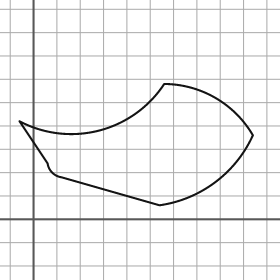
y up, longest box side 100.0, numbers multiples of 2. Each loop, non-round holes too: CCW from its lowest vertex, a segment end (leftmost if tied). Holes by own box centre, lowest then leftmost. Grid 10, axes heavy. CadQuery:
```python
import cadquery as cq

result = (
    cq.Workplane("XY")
    .moveTo(54.0, 6.0)
    .threePointArc((78.0, 16.0), (94.0, 36.0))
    .threePointArc((78.0, 52.0), (56.0, 58.0))
    .threePointArc((28.0, 38.0), (-6.0, 42.0))
    .lineTo(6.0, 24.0)
    .threePointArc((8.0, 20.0), (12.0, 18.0))
    .close()
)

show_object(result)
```